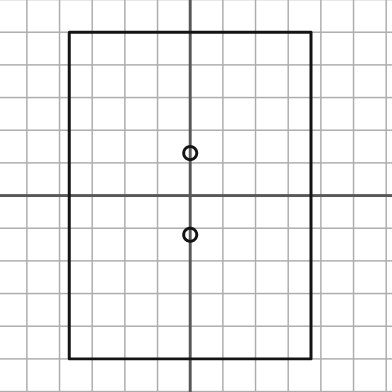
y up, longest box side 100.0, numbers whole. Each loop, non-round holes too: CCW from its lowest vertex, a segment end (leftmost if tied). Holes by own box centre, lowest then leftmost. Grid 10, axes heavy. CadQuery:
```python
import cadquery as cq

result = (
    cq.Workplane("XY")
    .moveTo(-37.0, -50.0)
    .lineTo(37.0, -50.0)
    .lineTo(37.0, 50.0)
    .lineTo(-37.0, 50.0)
    .close()
    .moveTo(0.0, -12.0)
    .circle(2.0)
    .moveTo(0.0, 13.0)
    .circle(2.0)
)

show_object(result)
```